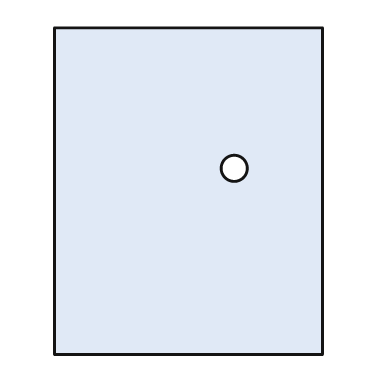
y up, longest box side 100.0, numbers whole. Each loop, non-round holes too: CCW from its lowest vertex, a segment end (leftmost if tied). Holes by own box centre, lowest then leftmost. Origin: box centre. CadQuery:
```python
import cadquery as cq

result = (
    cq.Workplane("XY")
    .moveTo(-41.0, -50.0)
    .lineTo(41.0, -50.0)
    .lineTo(41.0, 50.0)
    .lineTo(-41.0, 50.0)
    .close()
    .moveTo(14.0, 7.0)
    .circle(4.0)
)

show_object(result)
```